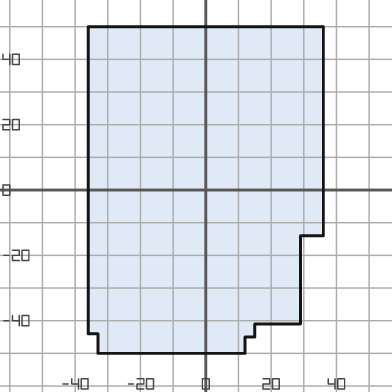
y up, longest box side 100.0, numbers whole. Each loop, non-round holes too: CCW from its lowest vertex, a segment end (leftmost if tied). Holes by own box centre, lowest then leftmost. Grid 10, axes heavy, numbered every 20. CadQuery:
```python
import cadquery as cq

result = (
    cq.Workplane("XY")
    .moveTo(-33.0, -50.0)
    .lineTo(12.0, -50.0)
    .lineTo(12.0, -45.0)
    .lineTo(15.0, -45.0)
    .lineTo(15.0, -41.0)
    .lineTo(29.0, -41.0)
    .lineTo(29.0, -14.0)
    .lineTo(36.0, -14.0)
    .lineTo(36.0, 50.0)
    .lineTo(-36.0, 50.0)
    .lineTo(-36.0, -44.0)
    .lineTo(-33.0, -44.0)
    .close()
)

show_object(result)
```